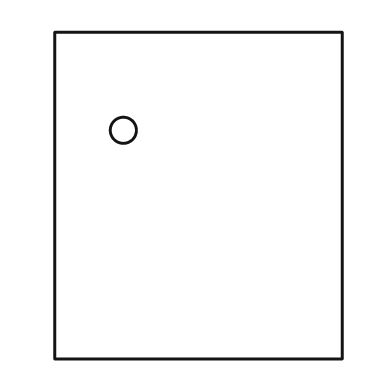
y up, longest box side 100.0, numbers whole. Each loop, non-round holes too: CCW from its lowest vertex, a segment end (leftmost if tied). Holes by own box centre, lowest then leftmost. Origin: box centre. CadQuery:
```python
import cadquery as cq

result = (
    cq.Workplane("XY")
    .moveTo(-44.0, -50.0)
    .lineTo(44.0, -50.0)
    .lineTo(44.0, 50.0)
    .lineTo(-44.0, 50.0)
    .close()
    .moveTo(-23.0, 20.0)
    .circle(4.0)
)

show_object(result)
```